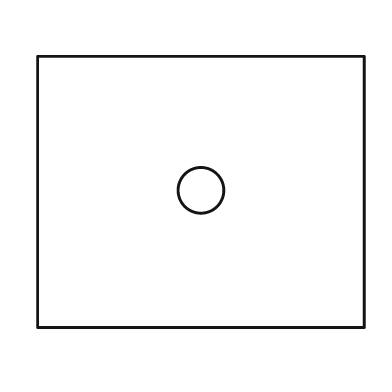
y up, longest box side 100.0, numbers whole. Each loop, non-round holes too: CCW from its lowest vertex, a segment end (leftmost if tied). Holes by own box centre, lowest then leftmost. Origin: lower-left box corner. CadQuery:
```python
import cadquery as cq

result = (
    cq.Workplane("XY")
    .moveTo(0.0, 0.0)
    .lineTo(100.0, 0.0)
    .lineTo(100.0, 83.0)
    .lineTo(0.0, 83.0)
    .close()
    .moveTo(50.0, 42.0)
    .circle(7.0)
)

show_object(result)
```